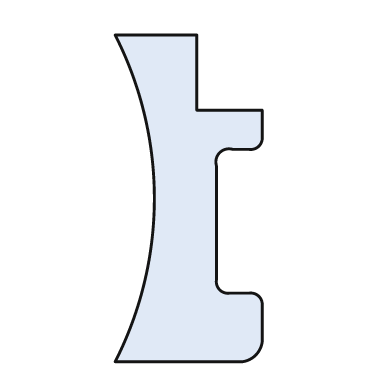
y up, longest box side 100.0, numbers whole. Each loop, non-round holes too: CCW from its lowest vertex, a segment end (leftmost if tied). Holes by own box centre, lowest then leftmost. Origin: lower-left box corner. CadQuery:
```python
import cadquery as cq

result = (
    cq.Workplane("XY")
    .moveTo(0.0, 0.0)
    .lineTo(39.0, 0.0)
    .threePointArc((43.0, 2.0), (45.0, 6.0))
    .lineTo(45.0, 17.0)
    .threePointArc((44.0, 20.0), (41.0, 21.0))
    .lineTo(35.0, 21.0)
    .threePointArc((32.0, 22.0), (31.0, 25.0))
    .lineTo(31.0, 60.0)
    .threePointArc((32.0, 64.0), (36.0, 65.0))
    .lineTo(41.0, 65.0)
    .threePointArc((44.0, 66.0), (45.0, 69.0))
    .lineTo(45.0, 77.0)
    .lineTo(25.0, 77.0)
    .lineTo(25.0, 100.0)
    .lineTo(0.0, 100.0)
    .threePointArc((12.0, 50.0), (0.0, 0.0))
    .close()
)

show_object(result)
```